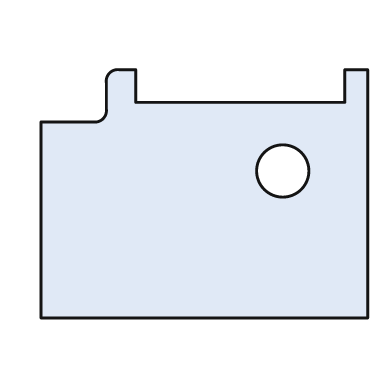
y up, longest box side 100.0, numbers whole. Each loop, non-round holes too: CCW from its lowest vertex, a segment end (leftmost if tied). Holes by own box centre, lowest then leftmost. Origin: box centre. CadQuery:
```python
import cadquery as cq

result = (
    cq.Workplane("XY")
    .moveTo(-50.0, -38.0)
    .lineTo(50.0, -38.0)
    .lineTo(50.0, 38.0)
    .lineTo(43.0, 38.0)
    .lineTo(43.0, 28.0)
    .lineTo(-21.0, 28.0)
    .lineTo(-21.0, 38.0)
    .lineTo(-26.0, 38.0)
    .threePointArc((-29.0, 37.0), (-30.0, 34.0))
    .lineTo(-30.0, 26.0)
    .threePointArc((-31.0, 23.0), (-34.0, 22.0))
    .lineTo(-50.0, 22.0)
    .close()
    .moveTo(24.0, 7.0)
    .circle(8.0)
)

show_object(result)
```